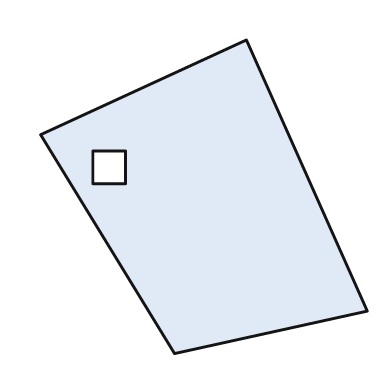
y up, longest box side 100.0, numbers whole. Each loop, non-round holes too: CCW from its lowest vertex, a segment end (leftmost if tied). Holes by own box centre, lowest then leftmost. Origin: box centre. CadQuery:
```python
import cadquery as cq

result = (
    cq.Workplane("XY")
    .moveTo(-9.0, -48.0)
    .lineTo(50.0, -35.0)
    .lineTo(13.0, 48.0)
    .lineTo(-50.0, 19.0)
    .close()
    .moveTo(-34.0, 4.0)
    .lineTo(-24.0, 4.0)
    .lineTo(-24.0, 14.0)
    .lineTo(-34.0, 14.0)
    .close()
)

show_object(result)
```